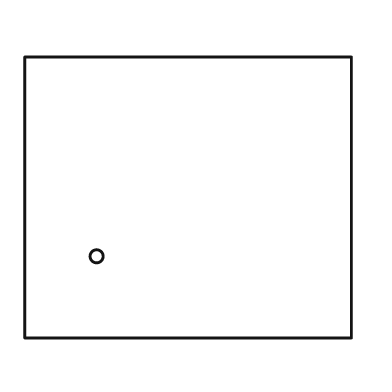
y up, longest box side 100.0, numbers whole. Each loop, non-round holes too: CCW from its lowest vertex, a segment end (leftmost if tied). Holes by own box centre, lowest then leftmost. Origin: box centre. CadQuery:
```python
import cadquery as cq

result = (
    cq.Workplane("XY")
    .moveTo(-50.0, -43.0)
    .lineTo(50.0, -43.0)
    .lineTo(50.0, 43.0)
    .lineTo(-50.0, 43.0)
    .close()
    .moveTo(-28.0, -18.0)
    .circle(2.0)
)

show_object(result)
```